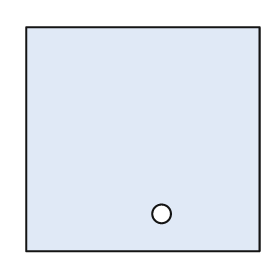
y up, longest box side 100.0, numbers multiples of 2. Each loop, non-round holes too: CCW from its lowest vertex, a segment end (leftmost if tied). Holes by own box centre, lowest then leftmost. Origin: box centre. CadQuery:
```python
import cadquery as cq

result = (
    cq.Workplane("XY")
    .moveTo(-50.0, -48.0)
    .lineTo(50.0, -48.0)
    .lineTo(50.0, 48.0)
    .lineTo(-50.0, 48.0)
    .close()
    .moveTo(8.0, -32.0)
    .circle(4.0)
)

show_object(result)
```